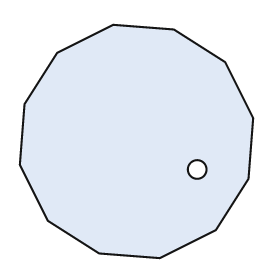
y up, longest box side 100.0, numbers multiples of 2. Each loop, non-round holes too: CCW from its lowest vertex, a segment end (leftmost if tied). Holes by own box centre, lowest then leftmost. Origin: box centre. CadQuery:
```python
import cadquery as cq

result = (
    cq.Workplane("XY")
    .moveTo(10.0, -50.0)
    .lineTo(34.0, -38.0)
    .lineTo(48.0, -16.0)
    .lineTo(50.0, 10.0)
    .lineTo(38.0, 34.0)
    .lineTo(16.0, 48.0)
    .lineTo(-10.0, 50.0)
    .lineTo(-34.0, 38.0)
    .lineTo(-48.0, 16.0)
    .lineTo(-50.0, -10.0)
    .lineTo(-38.0, -34.0)
    .lineTo(-16.0, -48.0)
    .close()
    .moveTo(26.0, -12.0)
    .circle(4.0)
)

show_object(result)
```